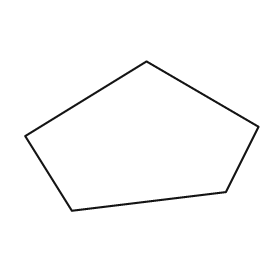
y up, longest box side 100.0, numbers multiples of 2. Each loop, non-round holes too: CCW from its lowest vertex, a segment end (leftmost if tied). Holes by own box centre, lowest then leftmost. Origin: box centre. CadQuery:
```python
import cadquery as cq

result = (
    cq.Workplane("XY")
    .moveTo(-30.0, -32.0)
    .lineTo(36.0, -24.0)
    .lineTo(50.0, 4.0)
    .lineTo(2.0, 32.0)
    .lineTo(-50.0, 0.0)
    .close()
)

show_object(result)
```